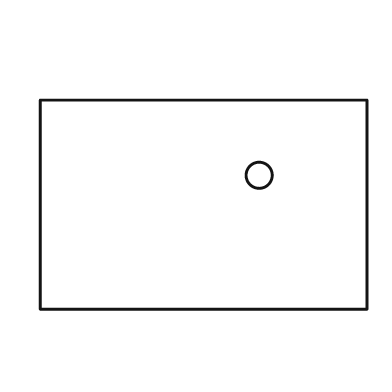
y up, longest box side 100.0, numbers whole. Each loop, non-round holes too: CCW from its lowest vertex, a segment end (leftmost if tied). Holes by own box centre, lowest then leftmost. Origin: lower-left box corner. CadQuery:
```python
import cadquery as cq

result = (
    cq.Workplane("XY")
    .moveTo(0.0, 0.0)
    .lineTo(100.0, 0.0)
    .lineTo(100.0, 64.0)
    .lineTo(0.0, 64.0)
    .close()
    .moveTo(67.0, 41.0)
    .circle(4.0)
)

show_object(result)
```